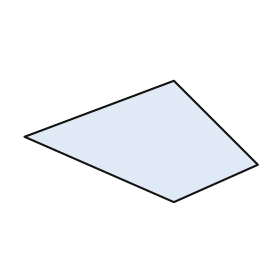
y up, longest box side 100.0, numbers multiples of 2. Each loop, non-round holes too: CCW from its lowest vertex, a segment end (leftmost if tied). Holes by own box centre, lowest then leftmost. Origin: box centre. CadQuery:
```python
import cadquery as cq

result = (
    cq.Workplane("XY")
    .moveTo(14.0, -26.0)
    .lineTo(50.0, -10.0)
    .lineTo(14.0, 26.0)
    .lineTo(-50.0, 2.0)
    .close()
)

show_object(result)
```